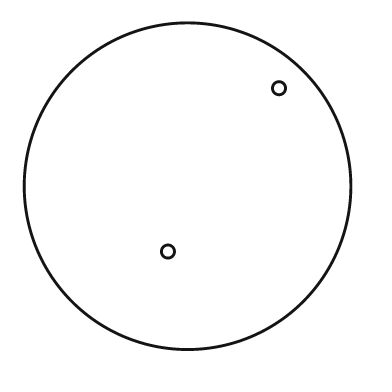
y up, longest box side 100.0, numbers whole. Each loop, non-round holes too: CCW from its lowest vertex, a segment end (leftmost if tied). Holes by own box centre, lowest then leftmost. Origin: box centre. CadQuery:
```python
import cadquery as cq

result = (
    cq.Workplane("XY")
    .moveTo(0.0, 0.0)
    .circle(50.0)
    .moveTo(-6.0, -20.0)
    .circle(2.0)
    .moveTo(28.0, 30.0)
    .circle(2.0)
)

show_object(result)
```